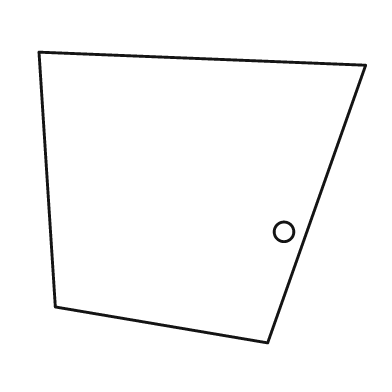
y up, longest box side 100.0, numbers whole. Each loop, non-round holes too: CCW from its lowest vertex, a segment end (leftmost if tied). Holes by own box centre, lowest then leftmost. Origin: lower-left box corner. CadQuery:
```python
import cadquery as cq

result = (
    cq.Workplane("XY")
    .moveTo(70.0, 0.0)
    .lineTo(100.0, 85.0)
    .lineTo(0.0, 89.0)
    .lineTo(5.0, 11.0)
    .close()
    .moveTo(75.0, 34.0)
    .circle(3.0)
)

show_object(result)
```